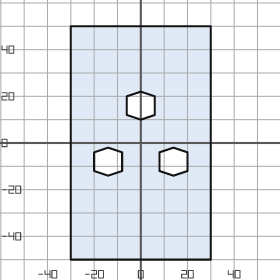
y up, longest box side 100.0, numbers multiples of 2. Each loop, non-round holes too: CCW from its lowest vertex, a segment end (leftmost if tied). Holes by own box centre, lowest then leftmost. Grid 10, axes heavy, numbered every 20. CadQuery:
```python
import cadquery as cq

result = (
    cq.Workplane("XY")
    .moveTo(-30.0, -50.0)
    .lineTo(30.0, -50.0)
    .lineTo(30.0, 50.0)
    .lineTo(-30.0, 50.0)
    .close()
    .moveTo(-14.0, -14.0)
    .lineTo(-8.0, -12.0)
    .lineTo(-8.0, -4.0)
    .lineTo(-14.0, -2.0)
    .lineTo(-20.0, -4.0)
    .lineTo(-20.0, -12.0)
    .close()
    .moveTo(14.0, -14.0)
    .lineTo(20.0, -12.0)
    .lineTo(20.0, -4.0)
    .lineTo(14.0, -2.0)
    .lineTo(8.0, -4.0)
    .lineTo(8.0, -12.0)
    .close()
    .moveTo(0.0, 10.0)
    .lineTo(6.0, 12.0)
    .lineTo(6.0, 20.0)
    .lineTo(0.0, 22.0)
    .lineTo(-6.0, 20.0)
    .lineTo(-6.0, 12.0)
    .close()
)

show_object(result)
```